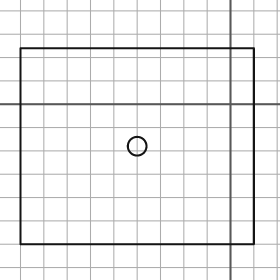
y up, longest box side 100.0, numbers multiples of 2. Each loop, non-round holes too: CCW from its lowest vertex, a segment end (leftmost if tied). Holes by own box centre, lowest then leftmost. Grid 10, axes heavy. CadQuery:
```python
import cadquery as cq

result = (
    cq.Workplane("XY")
    .moveTo(-90.0, -60.0)
    .lineTo(10.0, -60.0)
    .lineTo(10.0, 24.0)
    .lineTo(-90.0, 24.0)
    .close()
    .moveTo(-40.0, -18.0)
    .circle(4.0)
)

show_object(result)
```